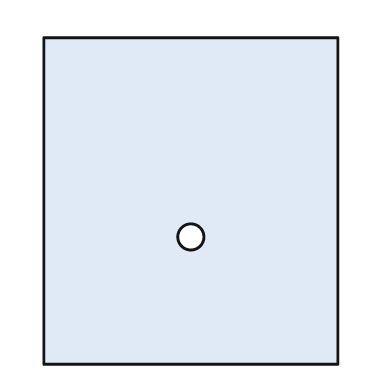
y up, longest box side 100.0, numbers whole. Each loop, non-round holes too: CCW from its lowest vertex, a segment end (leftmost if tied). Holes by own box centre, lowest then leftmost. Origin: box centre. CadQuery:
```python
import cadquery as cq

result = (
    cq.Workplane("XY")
    .moveTo(-45.0, -50.0)
    .lineTo(45.0, -50.0)
    .lineTo(45.0, 50.0)
    .lineTo(-45.0, 50.0)
    .close()
    .moveTo(0.0, -11.0)
    .circle(4.0)
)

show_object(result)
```